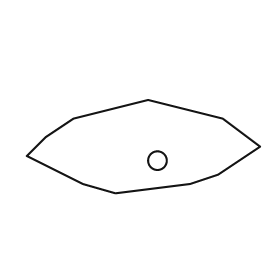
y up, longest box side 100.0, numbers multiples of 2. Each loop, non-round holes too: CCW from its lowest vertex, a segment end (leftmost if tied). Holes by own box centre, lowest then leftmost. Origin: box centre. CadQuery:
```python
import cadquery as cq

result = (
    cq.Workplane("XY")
    .moveTo(-12.0, -20.0)
    .lineTo(20.0, -16.0)
    .lineTo(32.0, -12.0)
    .lineTo(50.0, 0.0)
    .lineTo(34.0, 12.0)
    .lineTo(2.0, 20.0)
    .lineTo(-30.0, 12.0)
    .lineTo(-42.0, 4.0)
    .lineTo(-50.0, -4.0)
    .lineTo(-26.0, -16.0)
    .close()
    .moveTo(6.0, -6.0)
    .circle(4.0)
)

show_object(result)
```